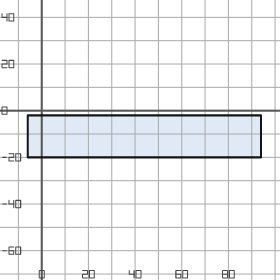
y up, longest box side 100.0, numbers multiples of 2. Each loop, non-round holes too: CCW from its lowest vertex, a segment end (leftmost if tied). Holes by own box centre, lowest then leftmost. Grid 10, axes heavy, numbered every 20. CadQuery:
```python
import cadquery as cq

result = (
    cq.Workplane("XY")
    .moveTo(-6.0, -20.0)
    .lineTo(94.0, -20.0)
    .lineTo(94.0, -2.0)
    .lineTo(-6.0, -2.0)
    .close()
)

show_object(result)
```